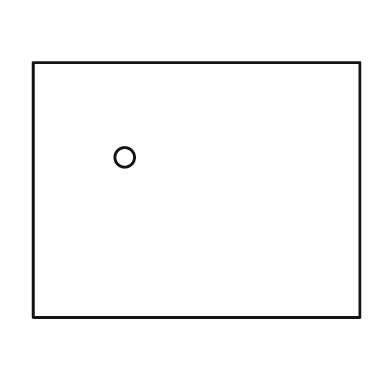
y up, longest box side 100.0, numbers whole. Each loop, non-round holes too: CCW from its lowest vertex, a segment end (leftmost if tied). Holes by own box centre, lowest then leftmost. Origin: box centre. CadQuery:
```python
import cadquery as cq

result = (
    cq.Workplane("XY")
    .moveTo(-50.0, -39.0)
    .lineTo(50.0, -39.0)
    .lineTo(50.0, 39.0)
    .lineTo(-50.0, 39.0)
    .close()
    .moveTo(-22.0, 10.0)
    .circle(3.0)
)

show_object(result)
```